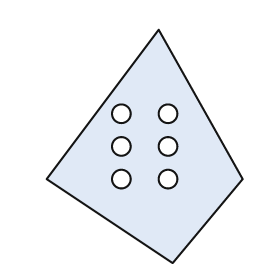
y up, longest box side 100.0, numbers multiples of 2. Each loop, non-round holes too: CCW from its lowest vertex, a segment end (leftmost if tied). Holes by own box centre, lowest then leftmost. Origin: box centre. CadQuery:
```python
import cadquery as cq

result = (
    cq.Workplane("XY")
    .moveTo(12.0, -50.0)
    .lineTo(42.0, -14.0)
    .lineTo(6.0, 50.0)
    .lineTo(-42.0, -14.0)
    .close()
    .moveTo(-10.0, -14.0)
    .circle(4.0)
    .moveTo(10.0, -14.0)
    .circle(4.0)
    .moveTo(-10.0, 0.0)
    .circle(4.0)
    .moveTo(10.0, 0.0)
    .circle(4.0)
    .moveTo(-10.0, 14.0)
    .circle(4.0)
    .moveTo(10.0, 14.0)
    .circle(4.0)
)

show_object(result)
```